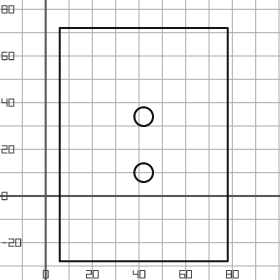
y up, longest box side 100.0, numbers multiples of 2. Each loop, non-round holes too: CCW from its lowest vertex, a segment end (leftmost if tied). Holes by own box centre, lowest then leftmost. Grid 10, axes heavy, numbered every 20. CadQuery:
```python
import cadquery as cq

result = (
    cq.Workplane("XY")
    .moveTo(6.0, -28.0)
    .lineTo(78.0, -28.0)
    .lineTo(78.0, 72.0)
    .lineTo(6.0, 72.0)
    .close()
    .moveTo(42.0, 10.0)
    .circle(4.0)
    .moveTo(42.0, 34.0)
    .circle(4.0)
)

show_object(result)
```